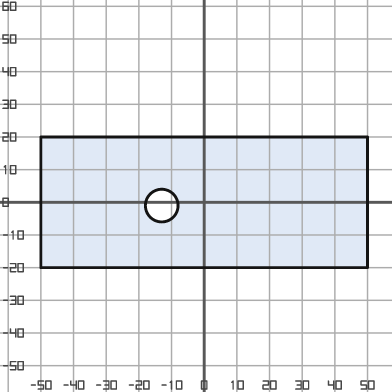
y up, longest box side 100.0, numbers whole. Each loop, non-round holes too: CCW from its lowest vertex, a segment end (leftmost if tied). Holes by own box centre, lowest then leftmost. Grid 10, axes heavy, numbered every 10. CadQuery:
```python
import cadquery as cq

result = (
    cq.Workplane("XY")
    .moveTo(-50.0, -20.0)
    .lineTo(50.0, -20.0)
    .lineTo(50.0, 20.0)
    .lineTo(-50.0, 20.0)
    .close()
    .moveTo(-13.0, -1.0)
    .circle(5.0)
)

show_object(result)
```